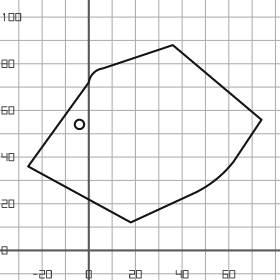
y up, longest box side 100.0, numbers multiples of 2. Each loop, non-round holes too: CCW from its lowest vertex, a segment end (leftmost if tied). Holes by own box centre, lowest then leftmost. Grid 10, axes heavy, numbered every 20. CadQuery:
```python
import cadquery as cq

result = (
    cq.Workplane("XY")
    .moveTo(18.0, 12.0)
    .lineTo(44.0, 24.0)
    .threePointArc((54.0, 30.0), (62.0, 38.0))
    .lineTo(74.0, 56.0)
    .lineTo(36.0, 88.0)
    .lineTo(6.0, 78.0)
    .threePointArc((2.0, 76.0), (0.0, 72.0))
    .lineTo(-26.0, 36.0)
    .close()
    .moveTo(-4.0, 54.0)
    .circle(2.0)
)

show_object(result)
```